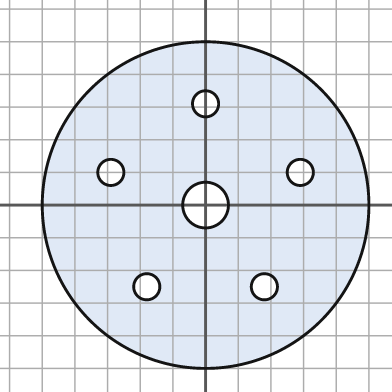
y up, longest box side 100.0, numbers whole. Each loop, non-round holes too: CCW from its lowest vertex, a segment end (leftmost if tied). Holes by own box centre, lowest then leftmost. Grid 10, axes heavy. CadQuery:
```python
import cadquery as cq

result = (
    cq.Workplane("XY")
    .moveTo(0.0, 0.0)
    .circle(50.0)
    .moveTo(-18.0, -25.0)
    .circle(4.0)
    .moveTo(18.0, -25.0)
    .circle(4.0)
    .moveTo(0.0, 0.0)
    .circle(7.0)
    .moveTo(-29.0, 10.0)
    .circle(4.0)
    .moveTo(29.0, 10.0)
    .circle(4.0)
    .moveTo(0.0, 31.0)
    .circle(4.0)
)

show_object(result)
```